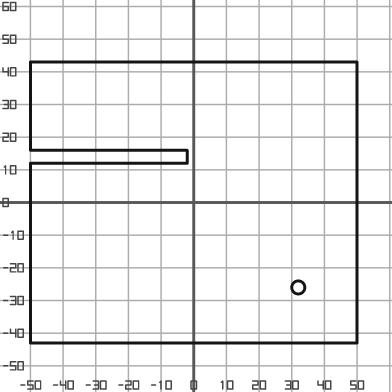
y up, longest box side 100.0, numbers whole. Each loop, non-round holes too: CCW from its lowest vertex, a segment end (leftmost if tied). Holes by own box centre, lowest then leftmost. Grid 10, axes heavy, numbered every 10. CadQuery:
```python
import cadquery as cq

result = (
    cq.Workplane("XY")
    .moveTo(-50.0, -43.0)
    .lineTo(50.0, -43.0)
    .lineTo(50.0, 43.0)
    .lineTo(-50.0, 43.0)
    .lineTo(-50.0, 16.0)
    .lineTo(-2.0, 16.0)
    .lineTo(-2.0, 12.0)
    .lineTo(-50.0, 12.0)
    .close()
    .moveTo(32.0, -26.0)
    .circle(2.0)
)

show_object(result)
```